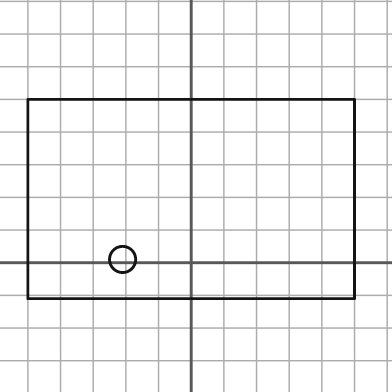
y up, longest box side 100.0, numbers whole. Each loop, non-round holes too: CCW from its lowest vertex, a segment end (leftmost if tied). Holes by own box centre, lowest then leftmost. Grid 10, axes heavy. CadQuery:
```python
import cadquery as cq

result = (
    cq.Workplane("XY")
    .moveTo(-50.0, -11.0)
    .lineTo(50.0, -11.0)
    .lineTo(50.0, 50.0)
    .lineTo(-50.0, 50.0)
    .close()
    .moveTo(-21.0, 1.0)
    .circle(4.0)
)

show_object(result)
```